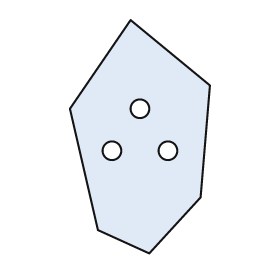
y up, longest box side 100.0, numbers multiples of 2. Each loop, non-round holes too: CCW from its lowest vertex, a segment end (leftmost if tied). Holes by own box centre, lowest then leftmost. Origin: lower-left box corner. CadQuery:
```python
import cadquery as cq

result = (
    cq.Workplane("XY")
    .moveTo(34.0, 0.0)
    .lineTo(56.0, 24.0)
    .lineTo(60.0, 72.0)
    .lineTo(26.0, 100.0)
    .lineTo(0.0, 62.0)
    .lineTo(12.0, 10.0)
    .close()
    .moveTo(18.0, 44.0)
    .circle(4.0)
    .moveTo(42.0, 44.0)
    .circle(4.0)
    .moveTo(30.0, 62.0)
    .circle(4.0)
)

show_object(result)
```